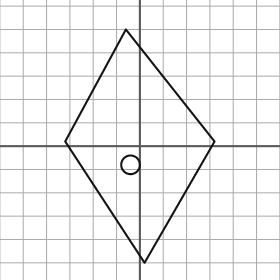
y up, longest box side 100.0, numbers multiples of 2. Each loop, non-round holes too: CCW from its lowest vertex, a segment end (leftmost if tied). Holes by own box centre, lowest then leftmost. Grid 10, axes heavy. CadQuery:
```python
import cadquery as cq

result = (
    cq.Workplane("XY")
    .moveTo(2.0, -50.0)
    .lineTo(32.0, 2.0)
    .lineTo(-6.0, 50.0)
    .lineTo(-32.0, 2.0)
    .close()
    .moveTo(-4.0, -8.0)
    .circle(4.0)
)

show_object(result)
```